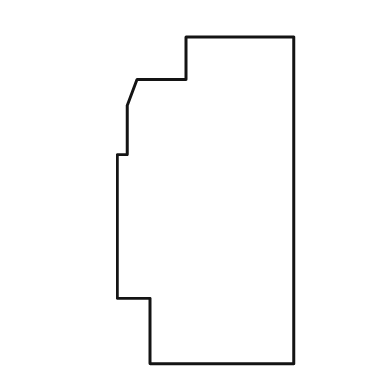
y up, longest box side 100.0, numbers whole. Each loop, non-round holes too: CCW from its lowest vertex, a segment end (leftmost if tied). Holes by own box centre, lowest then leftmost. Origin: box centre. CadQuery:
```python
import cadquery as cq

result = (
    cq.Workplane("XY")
    .moveTo(-17.0, -50.0)
    .lineTo(27.0, -50.0)
    .lineTo(27.0, 50.0)
    .lineTo(-6.0, 50.0)
    .lineTo(-6.0, 37.0)
    .lineTo(-21.0, 37.0)
    .lineTo(-24.0, 29.0)
    .lineTo(-24.0, 14.0)
    .lineTo(-27.0, 14.0)
    .lineTo(-27.0, -30.0)
    .lineTo(-17.0, -30.0)
    .close()
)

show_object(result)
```